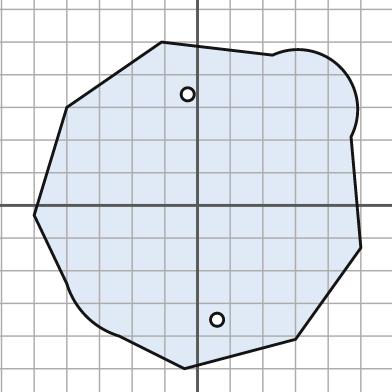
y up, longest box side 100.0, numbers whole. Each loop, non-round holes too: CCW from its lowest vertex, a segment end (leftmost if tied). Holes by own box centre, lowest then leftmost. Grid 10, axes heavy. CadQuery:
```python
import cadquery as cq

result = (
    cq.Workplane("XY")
    .moveTo(-4.0, -50.0)
    .lineTo(30.0, -41.0)
    .lineTo(50.0, -13.0)
    .lineTo(47.0, 21.0)
    .threePointArc((44.0, 42.0), (23.0, 46.0))
    .lineTo(-11.0, 50.0)
    .lineTo(-40.0, 30.0)
    .lineTo(-50.0, -3.0)
    .lineTo(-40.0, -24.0)
    .threePointArc((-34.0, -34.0), (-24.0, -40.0))
    .close()
    .moveTo(6.0, -35.0)
    .circle(2.0)
    .moveTo(-3.0, 34.0)
    .circle(2.0)
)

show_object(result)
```